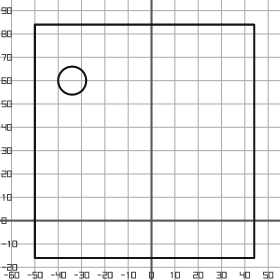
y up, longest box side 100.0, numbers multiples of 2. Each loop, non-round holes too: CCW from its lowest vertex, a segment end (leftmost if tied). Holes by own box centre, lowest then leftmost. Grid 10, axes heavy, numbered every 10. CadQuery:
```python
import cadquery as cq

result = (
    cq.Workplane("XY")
    .moveTo(-50.0, -16.0)
    .lineTo(44.0, -16.0)
    .lineTo(44.0, 84.0)
    .lineTo(-50.0, 84.0)
    .close()
    .moveTo(-34.0, 60.0)
    .circle(6.0)
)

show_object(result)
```